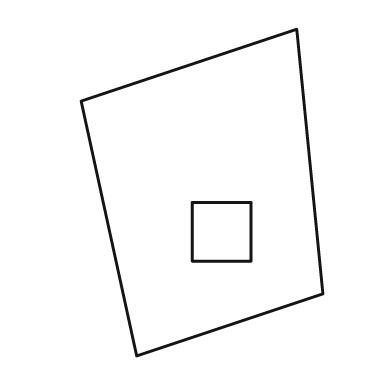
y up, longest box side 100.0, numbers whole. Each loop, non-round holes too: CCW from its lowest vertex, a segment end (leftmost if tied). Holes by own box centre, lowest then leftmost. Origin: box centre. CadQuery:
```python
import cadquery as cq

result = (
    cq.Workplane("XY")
    .moveTo(-20.0, -50.0)
    .lineTo(37.0, -31.0)
    .lineTo(29.0, 50.0)
    .lineTo(-37.0, 28.0)
    .close()
    .moveTo(-3.0, -21.0)
    .lineTo(15.0, -21.0)
    .lineTo(15.0, -3.0)
    .lineTo(-3.0, -3.0)
    .close()
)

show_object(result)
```